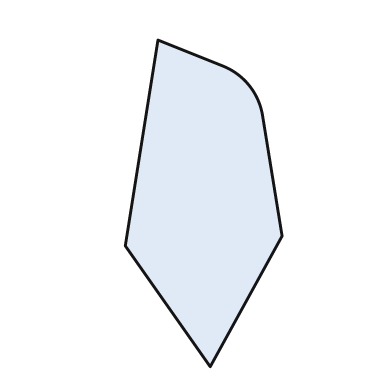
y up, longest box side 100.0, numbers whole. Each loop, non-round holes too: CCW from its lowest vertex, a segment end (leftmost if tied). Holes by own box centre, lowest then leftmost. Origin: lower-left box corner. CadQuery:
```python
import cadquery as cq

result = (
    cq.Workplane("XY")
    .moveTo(26.0, 0.0)
    .lineTo(48.0, 40.0)
    .lineTo(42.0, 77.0)
    .threePointArc((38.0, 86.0), (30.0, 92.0))
    .lineTo(10.0, 100.0)
    .lineTo(0.0, 37.0)
    .close()
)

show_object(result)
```